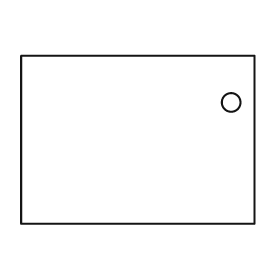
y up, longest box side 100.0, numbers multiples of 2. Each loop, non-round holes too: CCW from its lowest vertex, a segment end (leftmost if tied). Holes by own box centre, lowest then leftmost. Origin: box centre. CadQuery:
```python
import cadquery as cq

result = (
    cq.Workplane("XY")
    .moveTo(-50.0, -36.0)
    .lineTo(50.0, -36.0)
    .lineTo(50.0, 36.0)
    .lineTo(-50.0, 36.0)
    .close()
    .moveTo(40.0, 16.0)
    .circle(4.0)
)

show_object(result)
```